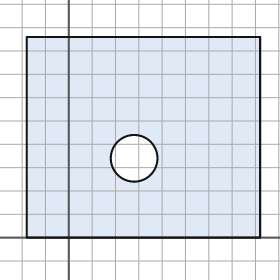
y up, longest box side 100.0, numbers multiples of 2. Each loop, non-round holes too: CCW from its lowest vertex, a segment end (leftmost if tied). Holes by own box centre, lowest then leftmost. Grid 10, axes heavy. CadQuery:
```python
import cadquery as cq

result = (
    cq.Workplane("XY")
    .moveTo(-18.0, 0.0)
    .lineTo(82.0, 0.0)
    .lineTo(82.0, 86.0)
    .lineTo(-18.0, 86.0)
    .close()
    .moveTo(28.0, 34.0)
    .circle(10.0)
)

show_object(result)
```